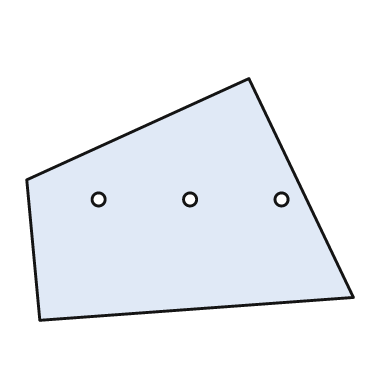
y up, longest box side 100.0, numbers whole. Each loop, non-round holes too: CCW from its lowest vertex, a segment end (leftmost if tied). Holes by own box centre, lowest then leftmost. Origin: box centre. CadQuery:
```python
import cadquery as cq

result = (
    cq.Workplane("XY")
    .moveTo(-46.0, -37.0)
    .lineTo(50.0, -30.0)
    .lineTo(18.0, 37.0)
    .lineTo(-50.0, 6.0)
    .close()
    .moveTo(-28.0, 0.0)
    .circle(2.0)
    .moveTo(0.0, 0.0)
    .circle(2.0)
    .moveTo(28.0, 0.0)
    .circle(2.0)
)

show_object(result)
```